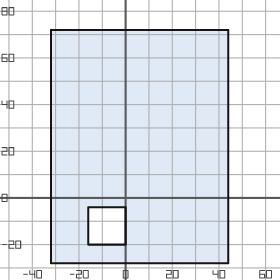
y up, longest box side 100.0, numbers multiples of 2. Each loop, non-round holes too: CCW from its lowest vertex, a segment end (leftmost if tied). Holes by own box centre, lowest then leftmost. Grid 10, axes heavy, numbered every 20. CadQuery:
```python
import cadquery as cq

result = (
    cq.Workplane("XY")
    .moveTo(-32.0, -28.0)
    .lineTo(44.0, -28.0)
    .lineTo(44.0, 72.0)
    .lineTo(-32.0, 72.0)
    .close()
    .moveTo(-16.0, -20.0)
    .lineTo(0.0, -20.0)
    .lineTo(0.0, -4.0)
    .lineTo(-16.0, -4.0)
    .close()
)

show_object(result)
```